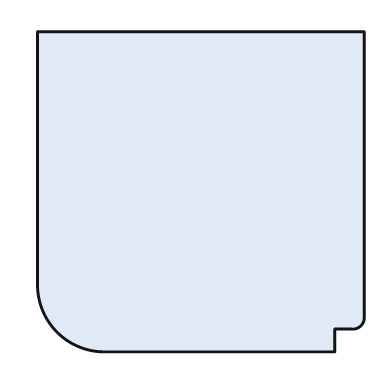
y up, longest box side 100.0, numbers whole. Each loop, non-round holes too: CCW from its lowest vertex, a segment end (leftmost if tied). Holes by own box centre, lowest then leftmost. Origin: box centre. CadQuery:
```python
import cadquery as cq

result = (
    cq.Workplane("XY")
    .moveTo(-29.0, -49.0)
    .lineTo(41.0, -49.0)
    .lineTo(41.0, -42.0)
    .lineTo(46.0, -42.0)
    .threePointArc((49.0, -41.0), (50.0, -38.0))
    .lineTo(50.0, 49.0)
    .lineTo(-50.0, 49.0)
    .lineTo(-50.0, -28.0)
    .threePointArc((-44.0, -43.0), (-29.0, -49.0))
    .close()
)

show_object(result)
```